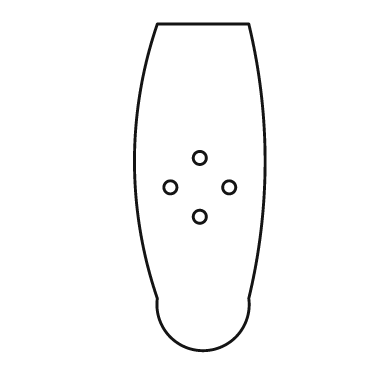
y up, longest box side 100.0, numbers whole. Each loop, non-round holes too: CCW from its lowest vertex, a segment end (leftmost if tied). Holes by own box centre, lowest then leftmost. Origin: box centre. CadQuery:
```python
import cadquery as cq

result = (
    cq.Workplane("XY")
    .moveTo(-13.0, -34.0)
    .threePointArc((1.0, -50.0), (15.0, -34.0))
    .threePointArc((20.0, 8.0), (15.0, 50.0))
    .lineTo(-13.0, 50.0)
    .threePointArc((-20.0, 8.0), (-13.0, -34.0))
    .close()
    .moveTo(0.0, -9.0)
    .circle(2.0)
    .moveTo(-9.0, 0.0)
    .circle(2.0)
    .moveTo(9.0, 0.0)
    .circle(2.0)
    .moveTo(0.0, 9.0)
    .circle(2.0)
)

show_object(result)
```